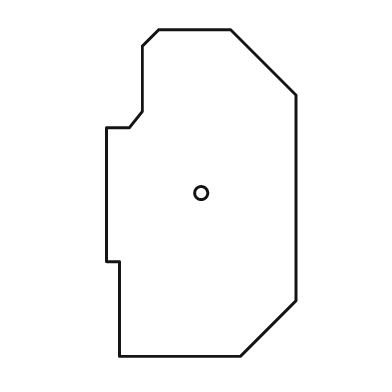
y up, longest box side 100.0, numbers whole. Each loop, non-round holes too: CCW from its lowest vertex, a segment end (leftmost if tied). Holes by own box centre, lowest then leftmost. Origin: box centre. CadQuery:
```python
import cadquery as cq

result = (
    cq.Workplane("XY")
    .moveTo(-25.0, -50.0)
    .lineTo(12.0, -50.0)
    .lineTo(29.0, -33.0)
    .lineTo(29.0, 30.0)
    .lineTo(9.0, 50.0)
    .lineTo(-13.0, 50.0)
    .lineTo(-18.0, 45.0)
    .lineTo(-18.0, 25.0)
    .lineTo(-22.0, 20.0)
    .lineTo(-29.0, 20.0)
    .lineTo(-29.0, -21.0)
    .lineTo(-25.0, -21.0)
    .close()
    .moveTo(0.0, 0.0)
    .circle(2.0)
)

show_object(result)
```